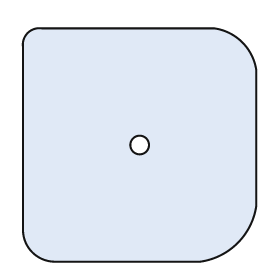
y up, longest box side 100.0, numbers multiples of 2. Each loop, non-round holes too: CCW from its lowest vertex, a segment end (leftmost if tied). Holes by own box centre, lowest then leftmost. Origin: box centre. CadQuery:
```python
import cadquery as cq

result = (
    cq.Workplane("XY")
    .moveTo(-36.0, -50.0)
    .lineTo(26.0, -50.0)
    .threePointArc((42.0, -42.0), (50.0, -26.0))
    .lineTo(50.0, 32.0)
    .threePointArc((44.0, 44.0), (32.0, 50.0))
    .lineTo(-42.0, 50.0)
    .threePointArc((-48.0, 48.0), (-50.0, 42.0))
    .lineTo(-50.0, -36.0)
    .threePointArc((-46.0, -46.0), (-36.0, -50.0))
    .close()
    .moveTo(0.0, 0.0)
    .circle(4.0)
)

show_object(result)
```